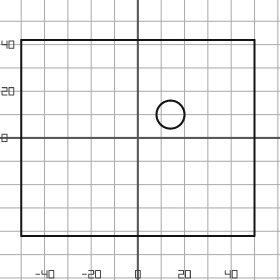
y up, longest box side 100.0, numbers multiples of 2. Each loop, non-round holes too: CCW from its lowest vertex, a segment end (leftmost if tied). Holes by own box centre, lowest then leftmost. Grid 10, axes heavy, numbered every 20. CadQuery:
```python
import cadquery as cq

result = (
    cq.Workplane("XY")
    .moveTo(-50.0, -42.0)
    .lineTo(50.0, -42.0)
    .lineTo(50.0, 42.0)
    .lineTo(-50.0, 42.0)
    .close()
    .moveTo(14.0, 10.0)
    .circle(6.0)
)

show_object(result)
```